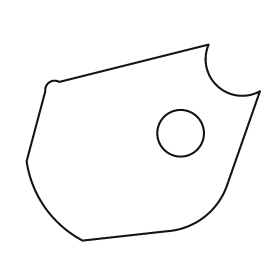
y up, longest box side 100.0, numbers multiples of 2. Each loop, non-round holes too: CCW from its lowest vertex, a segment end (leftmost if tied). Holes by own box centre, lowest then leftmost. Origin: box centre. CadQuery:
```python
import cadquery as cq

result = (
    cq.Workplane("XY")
    .moveTo(-26.0, -42.0)
    .lineTo(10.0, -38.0)
    .threePointArc((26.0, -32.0), (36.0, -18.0))
    .lineTo(50.0, 22.0)
    .threePointArc((32.0, 24.0), (28.0, 42.0))
    .lineTo(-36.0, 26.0)
    .threePointArc((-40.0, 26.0), (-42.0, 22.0))
    .lineTo(-50.0, -8.0)
    .threePointArc((-42.0, -28.0), (-26.0, -42.0))
    .close()
    .moveTo(16.0, 4.0)
    .circle(10.0)
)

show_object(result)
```